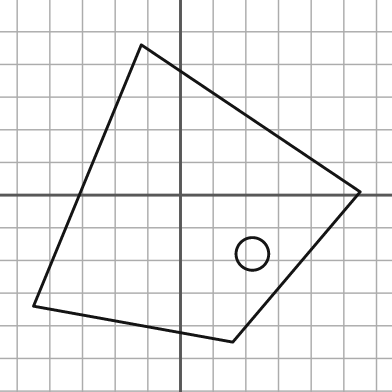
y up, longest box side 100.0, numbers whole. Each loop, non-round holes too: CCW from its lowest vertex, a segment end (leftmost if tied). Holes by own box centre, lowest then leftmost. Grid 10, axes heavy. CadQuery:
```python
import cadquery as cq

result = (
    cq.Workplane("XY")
    .moveTo(16.0, -45.0)
    .lineTo(55.0, 1.0)
    .lineTo(-12.0, 46.0)
    .lineTo(-45.0, -34.0)
    .close()
    .moveTo(22.0, -18.0)
    .circle(5.0)
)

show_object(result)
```